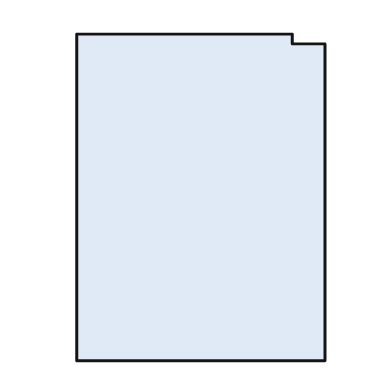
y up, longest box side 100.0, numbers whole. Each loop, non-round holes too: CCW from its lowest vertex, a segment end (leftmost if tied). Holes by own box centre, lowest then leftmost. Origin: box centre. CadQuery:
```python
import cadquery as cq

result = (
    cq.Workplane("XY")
    .moveTo(-38.0, -50.0)
    .lineTo(38.0, -50.0)
    .lineTo(38.0, 47.0)
    .lineTo(28.0, 47.0)
    .lineTo(28.0, 50.0)
    .lineTo(-38.0, 50.0)
    .close()
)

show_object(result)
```